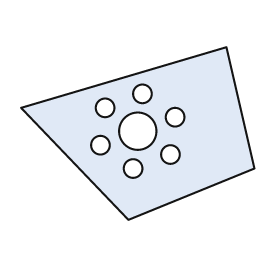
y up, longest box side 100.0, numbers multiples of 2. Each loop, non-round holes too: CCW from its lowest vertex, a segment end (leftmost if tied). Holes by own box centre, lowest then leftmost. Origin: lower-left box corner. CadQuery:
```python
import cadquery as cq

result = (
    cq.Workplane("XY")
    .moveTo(46.0, 0.0)
    .lineTo(100.0, 22.0)
    .lineTo(88.0, 74.0)
    .lineTo(0.0, 48.0)
    .close()
    .moveTo(48.0, 22.0)
    .circle(4.0)
    .moveTo(64.0, 28.0)
    .circle(4.0)
    .moveTo(34.0, 32.0)
    .circle(4.0)
    .moveTo(50.0, 38.0)
    .circle(8.0)
    .moveTo(66.0, 44.0)
    .circle(4.0)
    .moveTo(36.0, 48.0)
    .circle(4.0)
    .moveTo(52.0, 54.0)
    .circle(4.0)
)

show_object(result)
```